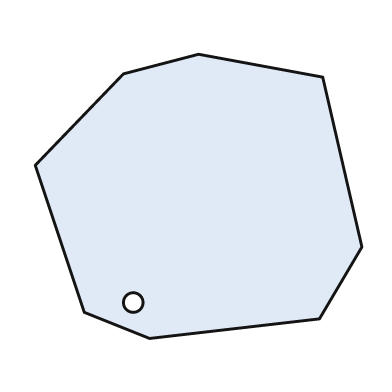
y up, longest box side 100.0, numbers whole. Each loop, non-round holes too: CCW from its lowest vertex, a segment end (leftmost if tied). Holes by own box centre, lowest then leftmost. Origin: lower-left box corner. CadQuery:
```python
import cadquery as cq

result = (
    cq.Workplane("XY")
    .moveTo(35.0, 0.0)
    .lineTo(87.0, 6.0)
    .lineTo(100.0, 28.0)
    .lineTo(88.0, 80.0)
    .lineTo(50.0, 87.0)
    .lineTo(27.0, 81.0)
    .lineTo(0.0, 53.0)
    .lineTo(15.0, 8.0)
    .close()
    .moveTo(30.0, 11.0)
    .circle(3.0)
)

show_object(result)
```